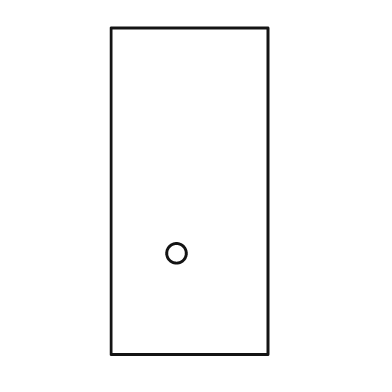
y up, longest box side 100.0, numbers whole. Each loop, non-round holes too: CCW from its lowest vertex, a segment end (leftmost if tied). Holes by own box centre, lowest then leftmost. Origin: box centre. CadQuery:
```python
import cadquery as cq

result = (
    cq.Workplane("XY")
    .moveTo(-24.0, -50.0)
    .lineTo(24.0, -50.0)
    .lineTo(24.0, 50.0)
    .lineTo(-24.0, 50.0)
    .close()
    .moveTo(-4.0, -19.0)
    .circle(3.0)
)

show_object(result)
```